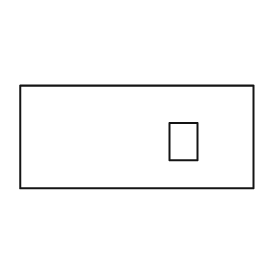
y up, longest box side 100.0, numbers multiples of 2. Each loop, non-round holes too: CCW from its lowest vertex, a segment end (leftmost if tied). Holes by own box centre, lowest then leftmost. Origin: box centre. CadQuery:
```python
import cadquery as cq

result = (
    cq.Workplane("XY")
    .moveTo(-50.0, -22.0)
    .lineTo(50.0, -22.0)
    .lineTo(50.0, 22.0)
    .lineTo(-50.0, 22.0)
    .close()
    .moveTo(14.0, -10.0)
    .lineTo(26.0, -10.0)
    .lineTo(26.0, 6.0)
    .lineTo(14.0, 6.0)
    .close()
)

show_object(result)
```